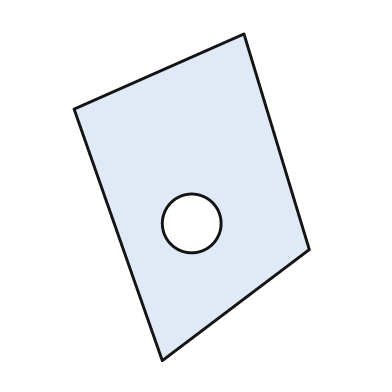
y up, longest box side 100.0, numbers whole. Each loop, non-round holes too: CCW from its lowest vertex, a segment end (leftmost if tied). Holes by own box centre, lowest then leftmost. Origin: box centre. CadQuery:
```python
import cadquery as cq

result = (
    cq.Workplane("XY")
    .moveTo(-9.0, -50.0)
    .lineTo(36.0, -16.0)
    .lineTo(16.0, 50.0)
    .lineTo(-36.0, 27.0)
    .close()
    .moveTo(0.0, -8.0)
    .circle(9.0)
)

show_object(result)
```